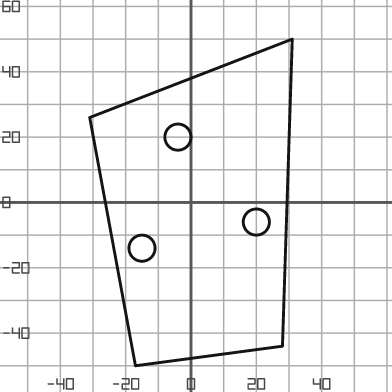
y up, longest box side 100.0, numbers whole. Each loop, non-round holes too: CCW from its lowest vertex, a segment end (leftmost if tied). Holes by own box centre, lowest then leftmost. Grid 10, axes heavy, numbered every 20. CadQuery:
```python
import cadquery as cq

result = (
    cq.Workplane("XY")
    .moveTo(-17.0, -50.0)
    .lineTo(28.0, -44.0)
    .lineTo(31.0, 50.0)
    .lineTo(-31.0, 26.0)
    .close()
    .moveTo(-15.0, -14.0)
    .circle(4.0)
    .moveTo(20.0, -6.0)
    .circle(4.0)
    .moveTo(-4.0, 20.0)
    .circle(4.0)
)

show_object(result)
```